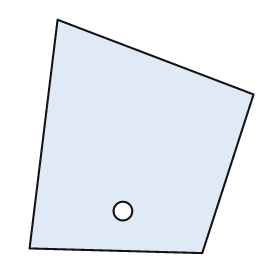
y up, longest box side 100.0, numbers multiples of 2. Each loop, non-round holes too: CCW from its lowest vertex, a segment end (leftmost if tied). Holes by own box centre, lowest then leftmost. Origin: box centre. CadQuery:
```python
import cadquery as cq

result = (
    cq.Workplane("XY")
    .moveTo(26.0, -50.0)
    .lineTo(48.0, 18.0)
    .lineTo(-36.0, 50.0)
    .lineTo(-48.0, -48.0)
    .close()
    .moveTo(-8.0, -32.0)
    .circle(4.0)
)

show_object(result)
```